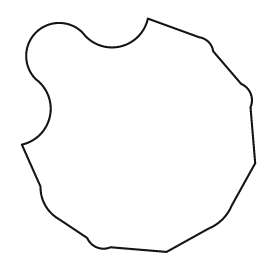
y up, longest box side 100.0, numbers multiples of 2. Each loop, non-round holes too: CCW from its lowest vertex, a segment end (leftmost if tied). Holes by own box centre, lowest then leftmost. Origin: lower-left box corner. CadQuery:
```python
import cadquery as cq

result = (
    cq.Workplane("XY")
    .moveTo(62.0, 0.0)
    .lineTo(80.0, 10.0)
    .threePointArc((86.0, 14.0), (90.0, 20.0))
    .lineTo(100.0, 38.0)
    .lineTo(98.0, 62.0)
    .threePointArc((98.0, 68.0), (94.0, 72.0))
    .lineTo(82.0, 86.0)
    .threePointArc((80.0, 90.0), (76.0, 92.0))
    .lineTo(54.0, 100.0)
    .threePointArc((42.0, 88.0), (26.0, 94.0))
    .threePointArc((6.0, 94.0), (6.0, 74.0))
    .threePointArc((12.0, 58.0), (0.0, 46.0))
    .lineTo(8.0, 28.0)
    .threePointArc((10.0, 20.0), (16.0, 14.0))
    .lineTo(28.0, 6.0)
    .threePointArc((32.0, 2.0), (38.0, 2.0))
    .close()
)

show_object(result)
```